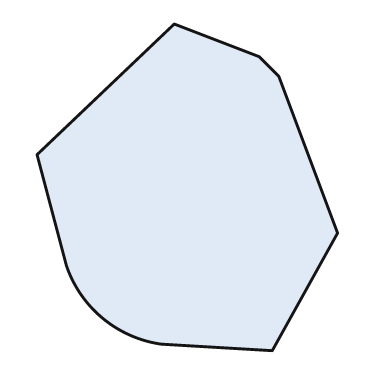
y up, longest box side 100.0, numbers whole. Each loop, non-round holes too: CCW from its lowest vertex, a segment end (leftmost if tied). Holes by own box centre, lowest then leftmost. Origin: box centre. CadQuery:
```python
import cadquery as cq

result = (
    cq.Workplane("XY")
    .moveTo(26.0, -50.0)
    .lineTo(46.0, -14.0)
    .lineTo(28.0, 34.0)
    .lineTo(22.0, 40.0)
    .lineTo(-4.0, 50.0)
    .lineTo(-46.0, 10.0)
    .lineTo(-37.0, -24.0)
    .threePointArc((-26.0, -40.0), (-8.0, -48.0))
    .close()
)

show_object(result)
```